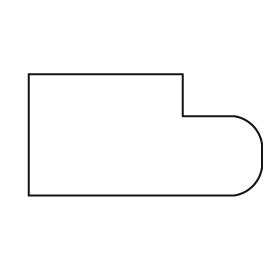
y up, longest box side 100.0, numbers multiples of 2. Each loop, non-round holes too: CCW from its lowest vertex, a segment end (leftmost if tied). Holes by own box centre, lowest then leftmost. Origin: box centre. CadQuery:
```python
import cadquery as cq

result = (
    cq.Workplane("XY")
    .moveTo(-50.0, -26.0)
    .lineTo(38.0, -26.0)
    .threePointArc((46.0, -22.0), (50.0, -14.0))
    .lineTo(50.0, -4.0)
    .threePointArc((46.0, 4.0), (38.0, 8.0))
    .lineTo(16.0, 8.0)
    .lineTo(16.0, 26.0)
    .lineTo(-50.0, 26.0)
    .close()
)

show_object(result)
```